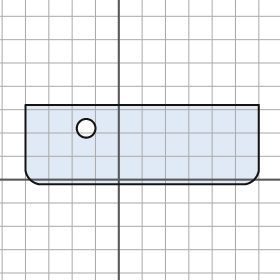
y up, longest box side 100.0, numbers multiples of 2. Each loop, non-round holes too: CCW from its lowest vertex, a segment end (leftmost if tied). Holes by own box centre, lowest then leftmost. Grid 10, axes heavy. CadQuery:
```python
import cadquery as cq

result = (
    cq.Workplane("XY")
    .moveTo(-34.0, -2.0)
    .lineTo(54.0, -2.0)
    .threePointArc((58.0, 0.0), (60.0, 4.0))
    .lineTo(60.0, 32.0)
    .lineTo(-40.0, 32.0)
    .lineTo(-40.0, 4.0)
    .threePointArc((-38.0, 0.0), (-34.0, -2.0))
    .close()
    .moveTo(-14.0, 22.0)
    .circle(4.0)
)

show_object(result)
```